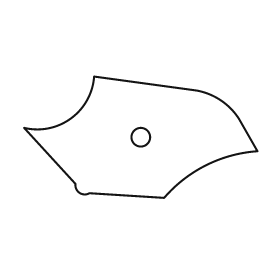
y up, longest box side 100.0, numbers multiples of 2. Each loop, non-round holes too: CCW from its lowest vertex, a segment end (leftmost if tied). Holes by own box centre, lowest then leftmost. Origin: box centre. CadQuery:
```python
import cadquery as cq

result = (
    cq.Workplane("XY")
    .moveTo(10.0, -26.0)
    .threePointArc((28.0, -12.0), (50.0, -6.0))
    .lineTo(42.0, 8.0)
    .threePointArc((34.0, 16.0), (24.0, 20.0))
    .lineTo(-20.0, 26.0)
    .threePointArc((-30.0, 8.0), (-50.0, 4.0))
    .lineTo(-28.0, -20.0)
    .threePointArc((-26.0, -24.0), (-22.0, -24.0))
    .close()
    .moveTo(0.0, 0.0)
    .circle(4.0)
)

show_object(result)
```